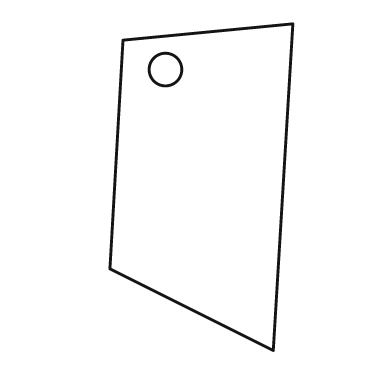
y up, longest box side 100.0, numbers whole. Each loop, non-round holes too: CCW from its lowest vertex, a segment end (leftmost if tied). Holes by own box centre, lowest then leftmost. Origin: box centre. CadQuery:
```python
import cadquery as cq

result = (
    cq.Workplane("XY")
    .moveTo(22.0, -50.0)
    .lineTo(28.0, 50.0)
    .lineTo(-24.0, 45.0)
    .lineTo(-28.0, -25.0)
    .close()
    .moveTo(-11.0, 36.0)
    .circle(5.0)
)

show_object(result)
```